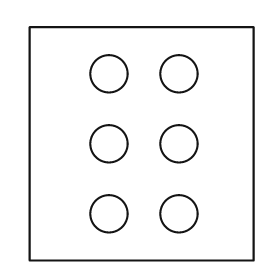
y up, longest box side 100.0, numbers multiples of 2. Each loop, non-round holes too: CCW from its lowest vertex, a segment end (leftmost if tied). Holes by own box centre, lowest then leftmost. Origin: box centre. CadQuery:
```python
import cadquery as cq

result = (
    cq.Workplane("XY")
    .moveTo(-48.0, -50.0)
    .lineTo(48.0, -50.0)
    .lineTo(48.0, 50.0)
    .lineTo(-48.0, 50.0)
    .close()
    .moveTo(-14.0, -30.0)
    .circle(8.0)
    .moveTo(16.0, -30.0)
    .circle(8.0)
    .moveTo(-14.0, 0.0)
    .circle(8.0)
    .moveTo(16.0, 0.0)
    .circle(8.0)
    .moveTo(-14.0, 30.0)
    .circle(8.0)
    .moveTo(16.0, 30.0)
    .circle(8.0)
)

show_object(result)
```